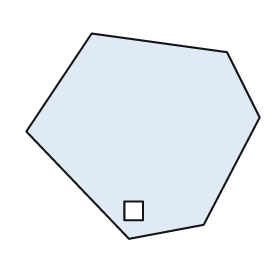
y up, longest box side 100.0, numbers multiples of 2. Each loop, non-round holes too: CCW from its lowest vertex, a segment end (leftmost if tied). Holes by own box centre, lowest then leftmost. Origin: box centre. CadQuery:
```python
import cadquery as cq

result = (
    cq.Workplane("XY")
    .moveTo(-6.0, -44.0)
    .lineTo(26.0, -38.0)
    .lineTo(50.0, 8.0)
    .lineTo(36.0, 36.0)
    .lineTo(-22.0, 44.0)
    .lineTo(-50.0, 2.0)
    .close()
    .moveTo(-8.0, -36.0)
    .lineTo(0.0, -36.0)
    .lineTo(0.0, -28.0)
    .lineTo(-8.0, -28.0)
    .close()
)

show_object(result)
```